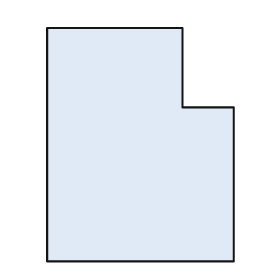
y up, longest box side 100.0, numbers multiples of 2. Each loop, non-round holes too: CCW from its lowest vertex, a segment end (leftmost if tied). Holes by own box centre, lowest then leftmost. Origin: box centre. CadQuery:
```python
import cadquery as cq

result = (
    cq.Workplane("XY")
    .moveTo(-40.0, -50.0)
    .lineTo(40.0, -50.0)
    .lineTo(40.0, 16.0)
    .lineTo(18.0, 16.0)
    .lineTo(18.0, 50.0)
    .lineTo(-40.0, 50.0)
    .close()
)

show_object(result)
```